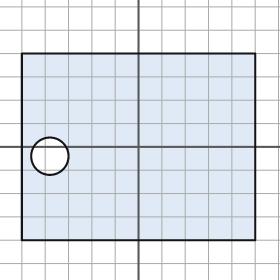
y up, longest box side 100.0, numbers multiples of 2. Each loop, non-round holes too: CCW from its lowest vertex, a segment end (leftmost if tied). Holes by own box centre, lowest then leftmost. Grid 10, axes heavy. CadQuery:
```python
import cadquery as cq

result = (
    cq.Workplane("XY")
    .moveTo(-50.0, -40.0)
    .lineTo(50.0, -40.0)
    .lineTo(50.0, 40.0)
    .lineTo(-50.0, 40.0)
    .close()
    .moveTo(-38.0, -4.0)
    .circle(8.0)
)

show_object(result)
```